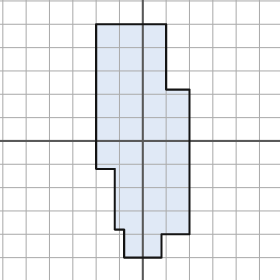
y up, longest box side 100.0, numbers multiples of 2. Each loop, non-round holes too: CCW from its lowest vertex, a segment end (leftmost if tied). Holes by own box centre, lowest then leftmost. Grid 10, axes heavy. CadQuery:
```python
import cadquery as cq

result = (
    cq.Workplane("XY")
    .moveTo(-8.0, -50.0)
    .lineTo(8.0, -50.0)
    .lineTo(8.0, -40.0)
    .lineTo(20.0, -40.0)
    .lineTo(20.0, 22.0)
    .lineTo(10.0, 22.0)
    .lineTo(10.0, 50.0)
    .lineTo(-20.0, 50.0)
    .lineTo(-20.0, -12.0)
    .lineTo(-12.0, -12.0)
    .lineTo(-12.0, -38.0)
    .lineTo(-8.0, -38.0)
    .close()
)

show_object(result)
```